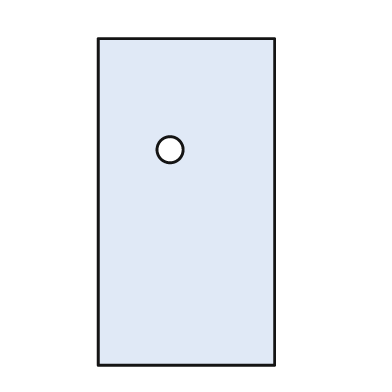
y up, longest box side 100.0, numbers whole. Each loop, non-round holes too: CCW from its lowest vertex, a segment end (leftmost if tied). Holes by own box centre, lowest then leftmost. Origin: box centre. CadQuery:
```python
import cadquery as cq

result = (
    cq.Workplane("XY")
    .moveTo(-27.0, -50.0)
    .lineTo(27.0, -50.0)
    .lineTo(27.0, 50.0)
    .lineTo(-27.0, 50.0)
    .close()
    .moveTo(-5.0, 16.0)
    .circle(4.0)
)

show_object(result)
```